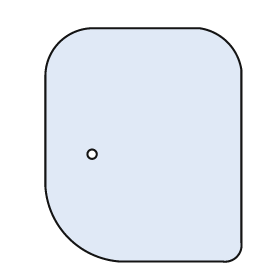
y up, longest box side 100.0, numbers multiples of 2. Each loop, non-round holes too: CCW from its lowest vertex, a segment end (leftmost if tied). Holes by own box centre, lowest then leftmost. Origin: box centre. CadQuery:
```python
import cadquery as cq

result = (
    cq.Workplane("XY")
    .moveTo(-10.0, -50.0)
    .lineTo(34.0, -50.0)
    .threePointArc((40.0, -48.0), (42.0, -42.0))
    .lineTo(42.0, 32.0)
    .threePointArc((36.0, 44.0), (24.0, 50.0))
    .lineTo(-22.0, 50.0)
    .threePointArc((-36.0, 44.0), (-42.0, 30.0))
    .lineTo(-42.0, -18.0)
    .threePointArc((-32.0, -40.0), (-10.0, -50.0))
    .close()
    .moveTo(-22.0, -4.0)
    .circle(2.0)
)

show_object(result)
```